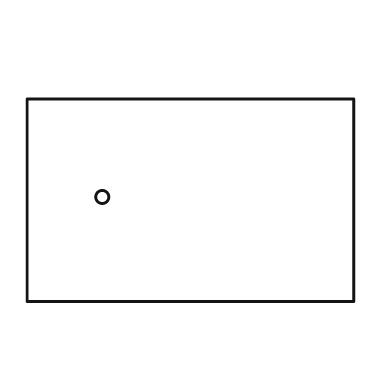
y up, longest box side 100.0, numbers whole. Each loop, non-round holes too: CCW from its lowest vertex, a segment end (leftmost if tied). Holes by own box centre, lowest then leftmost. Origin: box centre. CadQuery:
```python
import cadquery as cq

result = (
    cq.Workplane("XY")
    .moveTo(-50.0, -31.0)
    .lineTo(50.0, -31.0)
    .lineTo(50.0, 31.0)
    .lineTo(-50.0, 31.0)
    .close()
    .moveTo(-27.0, 1.0)
    .circle(2.0)
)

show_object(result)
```